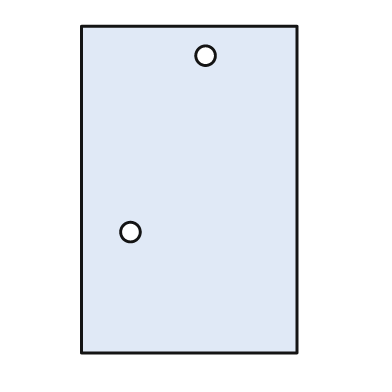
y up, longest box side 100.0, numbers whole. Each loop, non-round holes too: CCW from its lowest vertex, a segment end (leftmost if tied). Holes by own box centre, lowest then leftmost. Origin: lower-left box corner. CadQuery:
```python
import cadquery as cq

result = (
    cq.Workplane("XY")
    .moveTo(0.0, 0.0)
    .lineTo(66.0, 0.0)
    .lineTo(66.0, 100.0)
    .lineTo(0.0, 100.0)
    .close()
    .moveTo(15.0, 37.0)
    .circle(3.0)
    .moveTo(38.0, 91.0)
    .circle(3.0)
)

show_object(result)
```